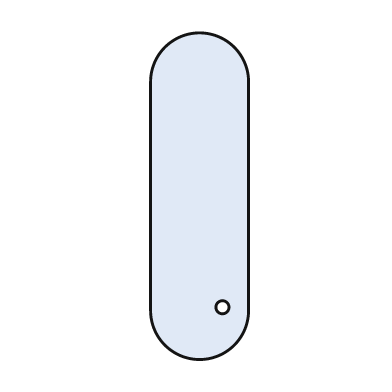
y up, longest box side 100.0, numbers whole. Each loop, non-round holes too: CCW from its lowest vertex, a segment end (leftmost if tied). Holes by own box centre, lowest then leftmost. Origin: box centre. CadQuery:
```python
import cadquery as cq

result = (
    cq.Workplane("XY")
    .moveTo(-15.0, -35.0)
    .threePointArc((0.0, -50.0), (15.0, -35.0))
    .lineTo(15.0, 35.0)
    .threePointArc((0.0, 50.0), (-15.0, 35.0))
    .close()
    .moveTo(7.0, -34.0)
    .circle(2.0)
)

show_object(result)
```